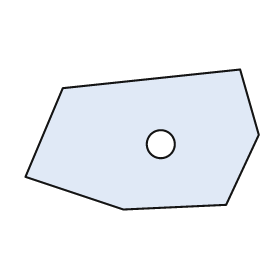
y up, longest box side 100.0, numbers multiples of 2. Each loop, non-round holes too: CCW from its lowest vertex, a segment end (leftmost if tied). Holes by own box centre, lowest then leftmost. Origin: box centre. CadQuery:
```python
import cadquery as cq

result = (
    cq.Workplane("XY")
    .moveTo(-8.0, -30.0)
    .lineTo(36.0, -28.0)
    .lineTo(50.0, 2.0)
    .lineTo(42.0, 30.0)
    .lineTo(-34.0, 22.0)
    .lineTo(-50.0, -16.0)
    .close()
    .moveTo(8.0, -2.0)
    .circle(6.0)
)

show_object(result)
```